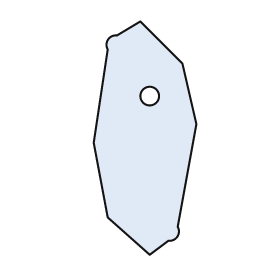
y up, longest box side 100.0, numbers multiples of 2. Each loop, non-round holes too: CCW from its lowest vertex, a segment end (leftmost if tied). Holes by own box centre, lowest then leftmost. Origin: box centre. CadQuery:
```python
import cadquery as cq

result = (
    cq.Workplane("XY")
    .moveTo(2.0, -50.0)
    .lineTo(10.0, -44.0)
    .threePointArc((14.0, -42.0), (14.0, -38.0))
    .lineTo(22.0, 6.0)
    .lineTo(16.0, 32.0)
    .lineTo(-2.0, 50.0)
    .lineTo(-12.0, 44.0)
    .threePointArc((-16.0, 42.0), (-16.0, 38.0))
    .lineTo(-22.0, -2.0)
    .lineTo(-16.0, -34.0)
    .close()
    .moveTo(2.0, 18.0)
    .circle(4.0)
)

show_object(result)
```